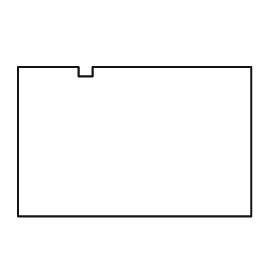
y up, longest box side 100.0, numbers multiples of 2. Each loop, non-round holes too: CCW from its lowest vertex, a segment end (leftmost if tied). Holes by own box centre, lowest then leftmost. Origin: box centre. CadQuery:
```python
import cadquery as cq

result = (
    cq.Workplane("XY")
    .moveTo(-50.0, -32.0)
    .lineTo(50.0, -32.0)
    .lineTo(50.0, 32.0)
    .lineTo(-18.0, 32.0)
    .lineTo(-18.0, 28.0)
    .lineTo(-24.0, 28.0)
    .lineTo(-24.0, 32.0)
    .lineTo(-50.0, 32.0)
    .close()
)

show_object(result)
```